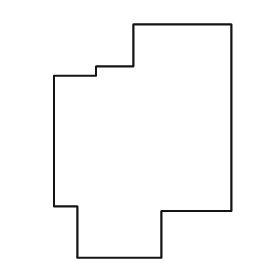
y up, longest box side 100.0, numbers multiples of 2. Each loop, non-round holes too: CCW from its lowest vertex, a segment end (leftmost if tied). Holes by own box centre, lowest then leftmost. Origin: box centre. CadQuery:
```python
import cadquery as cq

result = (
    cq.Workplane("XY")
    .moveTo(-28.0, -50.0)
    .lineTo(8.0, -50.0)
    .lineTo(8.0, -30.0)
    .lineTo(38.0, -30.0)
    .lineTo(38.0, 50.0)
    .lineTo(-4.0, 50.0)
    .lineTo(-4.0, 32.0)
    .lineTo(-20.0, 32.0)
    .lineTo(-20.0, 28.0)
    .lineTo(-38.0, 28.0)
    .lineTo(-38.0, -28.0)
    .lineTo(-28.0, -28.0)
    .close()
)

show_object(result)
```